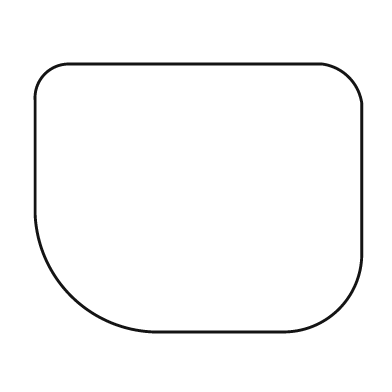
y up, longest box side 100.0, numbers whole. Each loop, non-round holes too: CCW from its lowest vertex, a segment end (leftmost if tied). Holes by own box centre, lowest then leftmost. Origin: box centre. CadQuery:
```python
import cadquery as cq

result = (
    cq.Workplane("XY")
    .moveTo(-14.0, -41.0)
    .lineTo(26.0, -41.0)
    .threePointArc((43.0, -34.0), (50.0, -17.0))
    .lineTo(50.0, 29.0)
    .threePointArc((46.0, 37.0), (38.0, 41.0))
    .lineTo(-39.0, 41.0)
    .threePointArc((-47.0, 38.0), (-50.0, 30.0))
    .lineTo(-50.0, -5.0)
    .threePointArc((-39.0, -30.0), (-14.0, -41.0))
    .close()
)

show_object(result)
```